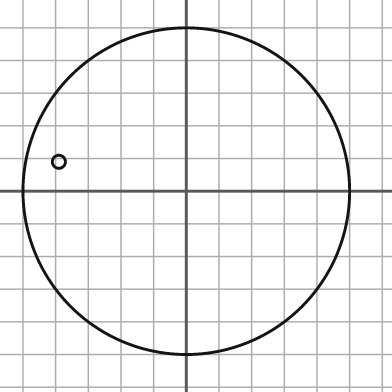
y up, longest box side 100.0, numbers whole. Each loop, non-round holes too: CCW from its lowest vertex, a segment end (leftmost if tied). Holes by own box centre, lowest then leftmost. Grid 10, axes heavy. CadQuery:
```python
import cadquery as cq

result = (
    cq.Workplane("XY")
    .moveTo(0.0, 0.0)
    .circle(50.0)
    .moveTo(-39.0, 9.0)
    .circle(2.0)
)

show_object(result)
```